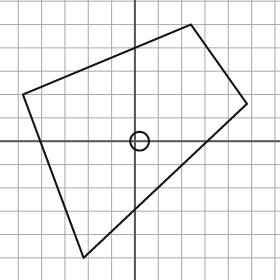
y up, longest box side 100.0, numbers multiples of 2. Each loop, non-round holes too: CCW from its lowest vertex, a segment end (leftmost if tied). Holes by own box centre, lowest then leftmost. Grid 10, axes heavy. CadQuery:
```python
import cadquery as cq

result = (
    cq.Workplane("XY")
    .moveTo(-22.0, -50.0)
    .lineTo(48.0, 16.0)
    .lineTo(24.0, 50.0)
    .lineTo(-48.0, 20.0)
    .close()
    .moveTo(2.0, 0.0)
    .circle(4.0)
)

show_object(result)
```